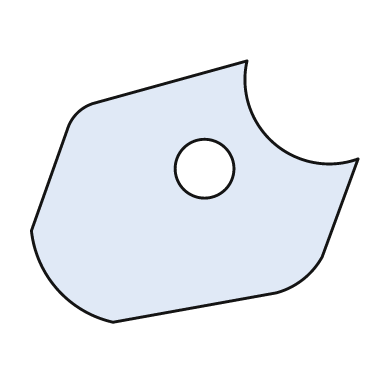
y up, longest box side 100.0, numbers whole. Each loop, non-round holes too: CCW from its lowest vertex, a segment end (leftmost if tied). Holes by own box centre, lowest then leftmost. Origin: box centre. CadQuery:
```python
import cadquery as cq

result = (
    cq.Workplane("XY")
    .moveTo(-25.0, -40.0)
    .lineTo(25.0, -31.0)
    .threePointArc((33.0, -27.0), (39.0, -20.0))
    .lineTo(50.0, 10.0)
    .threePointArc((24.0, 15.0), (16.0, 40.0))
    .lineTo(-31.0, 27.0)
    .threePointArc((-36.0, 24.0), (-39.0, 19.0))
    .lineTo(-50.0, -12.0)
    .threePointArc((-42.0, -30.0), (-25.0, -40.0))
    .close()
    .moveTo(3.0, 7.0)
    .circle(9.0)
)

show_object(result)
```